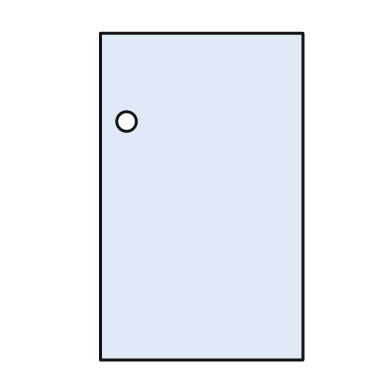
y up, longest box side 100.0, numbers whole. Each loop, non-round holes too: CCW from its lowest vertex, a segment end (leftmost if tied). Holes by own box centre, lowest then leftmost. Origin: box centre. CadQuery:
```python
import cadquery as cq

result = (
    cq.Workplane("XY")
    .moveTo(-31.0, -50.0)
    .lineTo(31.0, -50.0)
    .lineTo(31.0, 50.0)
    .lineTo(-31.0, 50.0)
    .close()
    .moveTo(-23.0, 23.0)
    .circle(3.0)
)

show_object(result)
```